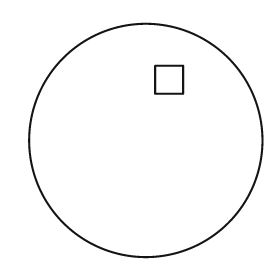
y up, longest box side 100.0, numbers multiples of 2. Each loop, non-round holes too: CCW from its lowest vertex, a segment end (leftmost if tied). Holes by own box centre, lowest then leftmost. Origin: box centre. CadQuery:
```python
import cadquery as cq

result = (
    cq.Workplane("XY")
    .moveTo(0.0, 0.0)
    .circle(50.0)
    .moveTo(4.0, 20.0)
    .lineTo(16.0, 20.0)
    .lineTo(16.0, 32.0)
    .lineTo(4.0, 32.0)
    .close()
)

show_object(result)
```